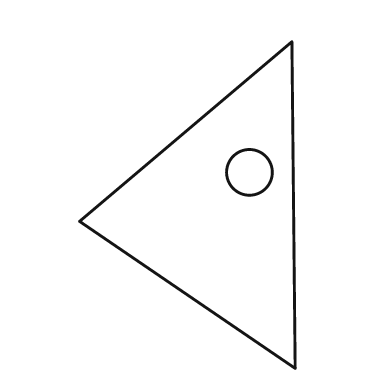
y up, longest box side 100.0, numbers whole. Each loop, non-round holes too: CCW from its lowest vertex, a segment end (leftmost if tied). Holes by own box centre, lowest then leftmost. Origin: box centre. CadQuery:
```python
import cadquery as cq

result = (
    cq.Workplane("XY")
    .moveTo(33.0, -50.0)
    .lineTo(32.0, 50.0)
    .lineTo(-33.0, -5.0)
    .close()
    .moveTo(19.0, 10.0)
    .circle(7.0)
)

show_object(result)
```